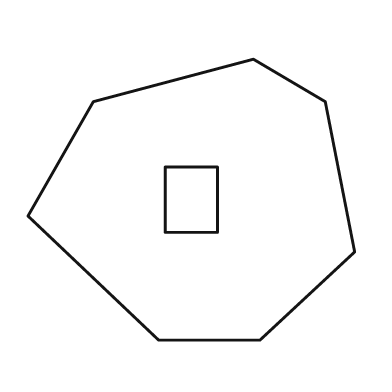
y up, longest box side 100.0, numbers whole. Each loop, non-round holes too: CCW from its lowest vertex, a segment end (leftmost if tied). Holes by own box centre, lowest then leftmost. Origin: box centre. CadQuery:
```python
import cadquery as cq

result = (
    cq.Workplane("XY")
    .moveTo(-10.0, -43.0)
    .lineTo(21.0, -43.0)
    .lineTo(50.0, -16.0)
    .lineTo(41.0, 30.0)
    .lineTo(19.0, 43.0)
    .lineTo(-30.0, 30.0)
    .lineTo(-50.0, -5.0)
    .close()
    .moveTo(-8.0, -10.0)
    .lineTo(8.0, -10.0)
    .lineTo(8.0, 10.0)
    .lineTo(-8.0, 10.0)
    .close()
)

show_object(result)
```